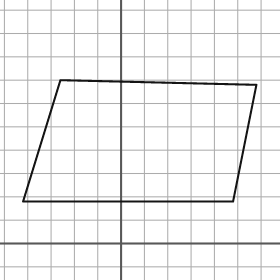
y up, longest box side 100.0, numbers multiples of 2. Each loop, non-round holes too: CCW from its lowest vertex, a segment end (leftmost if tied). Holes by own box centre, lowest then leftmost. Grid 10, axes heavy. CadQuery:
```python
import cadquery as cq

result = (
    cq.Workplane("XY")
    .moveTo(-42.0, 18.0)
    .lineTo(48.0, 18.0)
    .lineTo(58.0, 68.0)
    .lineTo(-26.0, 70.0)
    .close()
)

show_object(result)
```